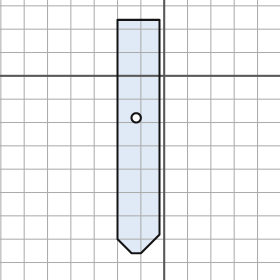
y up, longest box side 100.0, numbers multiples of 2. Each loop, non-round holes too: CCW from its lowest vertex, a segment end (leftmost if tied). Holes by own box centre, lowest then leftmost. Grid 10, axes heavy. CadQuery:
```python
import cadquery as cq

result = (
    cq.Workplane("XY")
    .moveTo(-14.0, -76.0)
    .lineTo(-10.0, -76.0)
    .lineTo(-2.0, -68.0)
    .lineTo(-2.0, 24.0)
    .lineTo(-20.0, 24.0)
    .lineTo(-20.0, -70.0)
    .close()
    .moveTo(-12.0, -18.0)
    .circle(2.0)
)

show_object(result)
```